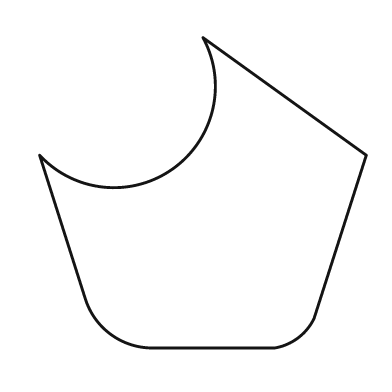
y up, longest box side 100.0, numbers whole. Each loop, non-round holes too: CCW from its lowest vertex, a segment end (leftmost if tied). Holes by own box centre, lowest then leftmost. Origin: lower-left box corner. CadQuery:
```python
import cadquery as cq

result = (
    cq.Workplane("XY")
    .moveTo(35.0, 0.0)
    .lineTo(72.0, 0.0)
    .threePointArc((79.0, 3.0), (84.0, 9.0))
    .lineTo(100.0, 59.0)
    .lineTo(50.0, 95.0)
    .threePointArc((41.0, 55.0), (0.0, 59.0))
    .lineTo(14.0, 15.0)
    .threePointArc((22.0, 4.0), (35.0, 0.0))
    .close()
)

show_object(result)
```